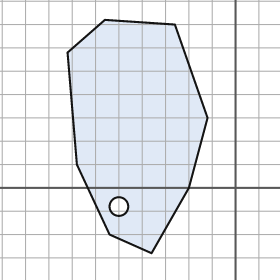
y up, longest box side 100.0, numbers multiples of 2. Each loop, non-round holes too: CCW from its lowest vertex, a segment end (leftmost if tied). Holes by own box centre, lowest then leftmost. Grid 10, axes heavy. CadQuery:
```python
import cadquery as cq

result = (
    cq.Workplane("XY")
    .moveTo(-36.0, -28.0)
    .lineTo(-20.0, 0.0)
    .lineTo(-12.0, 30.0)
    .lineTo(-26.0, 70.0)
    .lineTo(-56.0, 72.0)
    .lineTo(-72.0, 58.0)
    .lineTo(-68.0, 10.0)
    .lineTo(-54.0, -20.0)
    .close()
    .moveTo(-50.0, -8.0)
    .circle(4.0)
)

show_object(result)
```